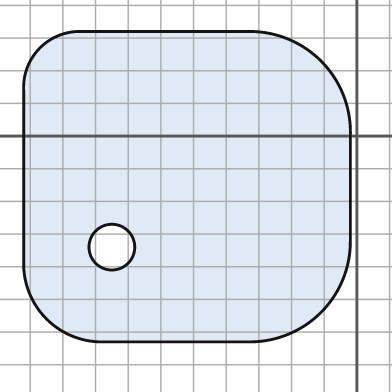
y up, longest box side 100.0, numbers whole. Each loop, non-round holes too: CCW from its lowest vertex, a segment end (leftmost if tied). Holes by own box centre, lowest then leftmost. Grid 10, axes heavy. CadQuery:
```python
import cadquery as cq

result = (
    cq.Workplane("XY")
    .moveTo(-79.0, -63.0)
    .lineTo(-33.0, -63.0)
    .threePointArc((-11.0, -54.0), (-2.0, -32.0))
    .lineTo(-2.0, 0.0)
    .threePointArc((-11.0, 23.0), (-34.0, 32.0))
    .lineTo(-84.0, 32.0)
    .threePointArc((-97.0, 27.0), (-102.0, 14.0))
    .lineTo(-102.0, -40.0)
    .threePointArc((-95.0, -56.0), (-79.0, -63.0))
    .close()
    .moveTo(-75.0, -34.0)
    .circle(7.0)
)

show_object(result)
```